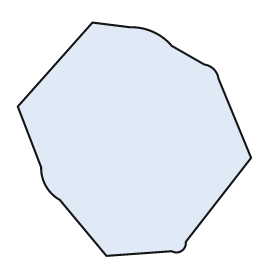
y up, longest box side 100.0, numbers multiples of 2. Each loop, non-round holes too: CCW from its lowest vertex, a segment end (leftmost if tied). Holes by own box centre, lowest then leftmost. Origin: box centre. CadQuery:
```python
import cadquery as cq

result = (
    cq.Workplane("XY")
    .moveTo(-12.0, -50.0)
    .lineTo(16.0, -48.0)
    .threePointArc((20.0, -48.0), (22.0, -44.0))
    .lineTo(50.0, -8.0)
    .lineTo(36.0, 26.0)
    .threePointArc((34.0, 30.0), (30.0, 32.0))
    .lineTo(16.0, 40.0)
    .threePointArc((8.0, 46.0), (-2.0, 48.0))
    .lineTo(-18.0, 50.0)
    .lineTo(-50.0, 14.0)
    .lineTo(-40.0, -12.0)
    .threePointArc((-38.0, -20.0), (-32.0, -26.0))
    .close()
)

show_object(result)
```